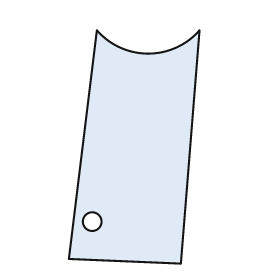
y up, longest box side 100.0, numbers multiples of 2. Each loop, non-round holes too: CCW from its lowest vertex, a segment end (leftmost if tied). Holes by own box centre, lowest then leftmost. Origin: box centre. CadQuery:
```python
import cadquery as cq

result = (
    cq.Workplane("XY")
    .moveTo(20.0, -50.0)
    .lineTo(28.0, 50.0)
    .threePointArc((6.0, 40.0), (-16.0, 50.0))
    .lineTo(-28.0, -48.0)
    .close()
    .moveTo(-18.0, -32.0)
    .circle(4.0)
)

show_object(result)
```